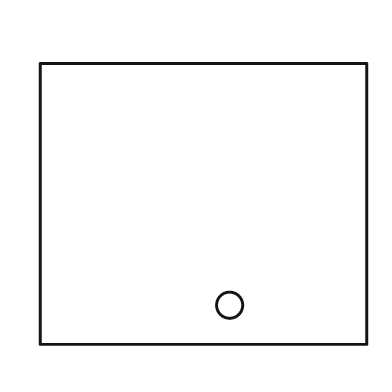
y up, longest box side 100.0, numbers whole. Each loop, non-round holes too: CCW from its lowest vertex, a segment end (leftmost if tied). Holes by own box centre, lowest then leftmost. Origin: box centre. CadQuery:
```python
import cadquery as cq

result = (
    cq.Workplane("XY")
    .moveTo(-50.0, -43.0)
    .lineTo(50.0, -43.0)
    .lineTo(50.0, 43.0)
    .lineTo(-50.0, 43.0)
    .close()
    .moveTo(8.0, -31.0)
    .circle(4.0)
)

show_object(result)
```